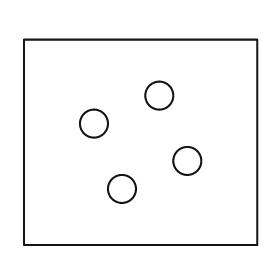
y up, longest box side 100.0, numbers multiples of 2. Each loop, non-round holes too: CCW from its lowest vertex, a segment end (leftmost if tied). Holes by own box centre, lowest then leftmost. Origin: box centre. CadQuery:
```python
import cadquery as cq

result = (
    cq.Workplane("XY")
    .moveTo(-50.0, -44.0)
    .lineTo(50.0, -44.0)
    .lineTo(50.0, 44.0)
    .lineTo(-50.0, 44.0)
    .close()
    .moveTo(-8.0, -20.0)
    .circle(6.0)
    .moveTo(20.0, -8.0)
    .circle(6.0)
    .moveTo(-20.0, 8.0)
    .circle(6.0)
    .moveTo(8.0, 20.0)
    .circle(6.0)
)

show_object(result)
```